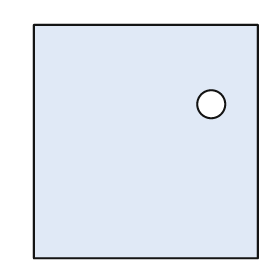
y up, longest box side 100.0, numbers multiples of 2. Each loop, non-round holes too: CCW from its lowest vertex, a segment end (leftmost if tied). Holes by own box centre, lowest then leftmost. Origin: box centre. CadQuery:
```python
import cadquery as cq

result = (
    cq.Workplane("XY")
    .moveTo(-48.0, -50.0)
    .lineTo(48.0, -50.0)
    .lineTo(48.0, 50.0)
    .lineTo(-48.0, 50.0)
    .close()
    .moveTo(28.0, 16.0)
    .circle(6.0)
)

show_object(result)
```